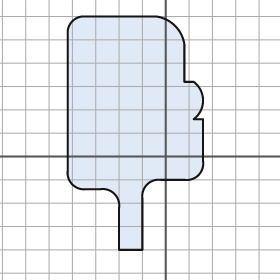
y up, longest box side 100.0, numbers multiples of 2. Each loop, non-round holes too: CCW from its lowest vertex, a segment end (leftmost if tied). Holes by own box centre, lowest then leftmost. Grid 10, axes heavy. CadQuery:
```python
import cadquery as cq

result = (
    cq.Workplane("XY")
    .moveTo(-20.0, -40.0)
    .lineTo(-10.0, -40.0)
    .lineTo(-10.0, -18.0)
    .threePointArc((-8.0, -12.0), (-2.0, -10.0))
    .lineTo(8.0, -10.0)
    .threePointArc((14.0, -8.0), (16.0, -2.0))
    .lineTo(16.0, 16.0)
    .lineTo(12.0, 16.0)
    .threePointArc((16.0, 24.0), (12.0, 32.0))
    .lineTo(8.0, 32.0)
    .lineTo(8.0, 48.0)
    .threePointArc((4.0, 56.0), (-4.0, 60.0))
    .lineTo(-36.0, 60.0)
    .threePointArc((-40.0, 58.0), (-42.0, 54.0))
    .lineTo(-42.0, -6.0)
    .threePointArc((-40.0, -12.0), (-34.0, -14.0))
    .lineTo(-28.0, -14.0)
    .threePointArc((-22.0, -16.0), (-20.0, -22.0))
    .close()
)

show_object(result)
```